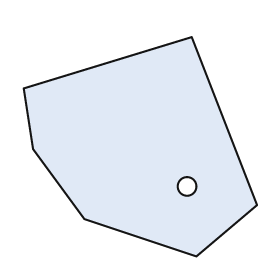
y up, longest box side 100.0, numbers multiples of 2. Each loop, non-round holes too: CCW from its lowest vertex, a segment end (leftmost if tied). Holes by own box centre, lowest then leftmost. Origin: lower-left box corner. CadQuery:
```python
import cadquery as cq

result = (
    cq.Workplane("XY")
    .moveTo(74.0, 0.0)
    .lineTo(100.0, 22.0)
    .lineTo(72.0, 94.0)
    .lineTo(0.0, 72.0)
    .lineTo(4.0, 46.0)
    .lineTo(26.0, 16.0)
    .close()
    .moveTo(70.0, 30.0)
    .circle(4.0)
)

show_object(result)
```